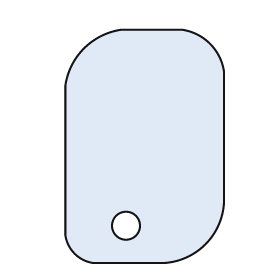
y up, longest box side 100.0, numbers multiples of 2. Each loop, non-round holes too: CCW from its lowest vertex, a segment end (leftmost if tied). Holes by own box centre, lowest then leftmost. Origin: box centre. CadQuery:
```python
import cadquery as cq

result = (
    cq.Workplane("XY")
    .moveTo(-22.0, -50.0)
    .lineTo(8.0, -50.0)
    .threePointArc((26.0, -42.0), (34.0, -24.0))
    .lineTo(34.0, 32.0)
    .threePointArc((28.0, 44.0), (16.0, 50.0))
    .lineTo(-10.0, 50.0)
    .threePointArc((-26.0, 42.0), (-34.0, 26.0))
    .lineTo(-34.0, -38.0)
    .threePointArc((-30.0, -46.0), (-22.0, -50.0))
    .close()
    .moveTo(-8.0, -34.0)
    .circle(6.0)
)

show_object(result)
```